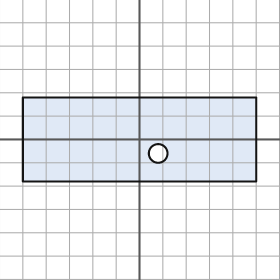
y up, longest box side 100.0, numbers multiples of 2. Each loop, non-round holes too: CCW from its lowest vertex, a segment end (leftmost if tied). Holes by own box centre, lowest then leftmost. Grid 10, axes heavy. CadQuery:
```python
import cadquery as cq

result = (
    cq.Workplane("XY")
    .moveTo(-50.0, -18.0)
    .lineTo(50.0, -18.0)
    .lineTo(50.0, 18.0)
    .lineTo(-50.0, 18.0)
    .close()
    .moveTo(8.0, -6.0)
    .circle(4.0)
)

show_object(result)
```